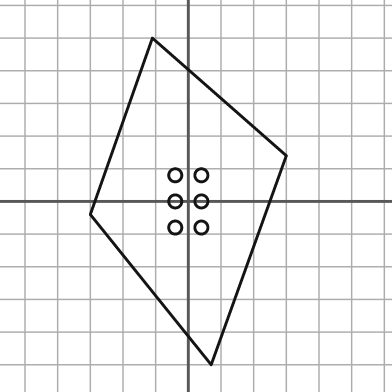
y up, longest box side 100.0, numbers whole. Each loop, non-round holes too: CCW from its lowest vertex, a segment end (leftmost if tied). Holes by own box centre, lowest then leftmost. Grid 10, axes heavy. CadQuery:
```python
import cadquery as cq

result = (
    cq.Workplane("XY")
    .moveTo(7.0, -50.0)
    .lineTo(30.0, 14.0)
    .lineTo(-11.0, 50.0)
    .lineTo(-30.0, -4.0)
    .close()
    .moveTo(-4.0, -8.0)
    .circle(2.0)
    .moveTo(4.0, -8.0)
    .circle(2.0)
    .moveTo(-4.0, 0.0)
    .circle(2.0)
    .moveTo(4.0, 0.0)
    .circle(2.0)
    .moveTo(-4.0, 8.0)
    .circle(2.0)
    .moveTo(4.0, 8.0)
    .circle(2.0)
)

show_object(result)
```